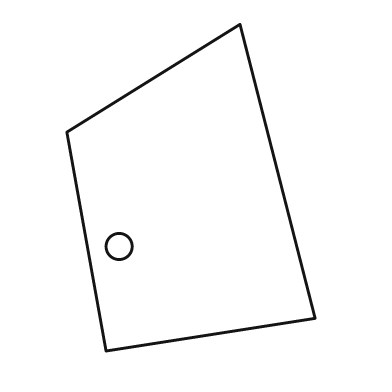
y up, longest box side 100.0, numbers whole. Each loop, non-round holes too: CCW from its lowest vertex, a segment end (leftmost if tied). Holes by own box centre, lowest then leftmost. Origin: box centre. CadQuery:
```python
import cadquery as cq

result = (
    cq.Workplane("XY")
    .moveTo(-26.0, -50.0)
    .lineTo(38.0, -40.0)
    .lineTo(15.0, 50.0)
    .lineTo(-38.0, 17.0)
    .close()
    .moveTo(-22.0, -18.0)
    .circle(4.0)
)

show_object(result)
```